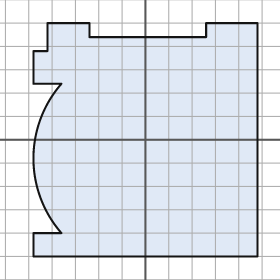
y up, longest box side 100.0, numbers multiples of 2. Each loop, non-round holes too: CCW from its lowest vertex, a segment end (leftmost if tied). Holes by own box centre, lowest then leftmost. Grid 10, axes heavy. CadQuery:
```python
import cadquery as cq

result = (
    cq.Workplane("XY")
    .moveTo(-48.0, -50.0)
    .lineTo(48.0, -50.0)
    .lineTo(48.0, 50.0)
    .lineTo(26.0, 50.0)
    .lineTo(26.0, 44.0)
    .lineTo(-24.0, 44.0)
    .lineTo(-24.0, 50.0)
    .lineTo(-42.0, 50.0)
    .lineTo(-42.0, 38.0)
    .lineTo(-48.0, 38.0)
    .lineTo(-48.0, 24.0)
    .lineTo(-36.0, 24.0)
    .threePointArc((-48.0, -8.0), (-36.0, -40.0))
    .lineTo(-48.0, -40.0)
    .close()
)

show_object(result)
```